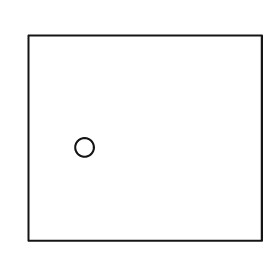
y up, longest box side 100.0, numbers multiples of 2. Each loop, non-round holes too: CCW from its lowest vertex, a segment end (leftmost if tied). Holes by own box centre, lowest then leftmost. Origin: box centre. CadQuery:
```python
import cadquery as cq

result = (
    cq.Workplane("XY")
    .moveTo(-50.0, -44.0)
    .lineTo(50.0, -44.0)
    .lineTo(50.0, 44.0)
    .lineTo(-50.0, 44.0)
    .close()
    .moveTo(-26.0, -4.0)
    .circle(4.0)
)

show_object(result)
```